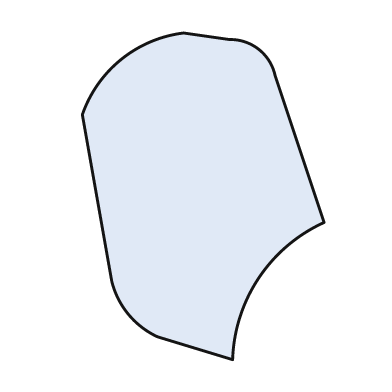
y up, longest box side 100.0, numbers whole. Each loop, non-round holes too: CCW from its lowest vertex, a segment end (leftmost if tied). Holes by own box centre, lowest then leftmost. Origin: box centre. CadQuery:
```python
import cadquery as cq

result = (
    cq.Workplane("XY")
    .moveTo(9.0, -50.0)
    .threePointArc((17.0, -25.0), (37.0, -8.0))
    .lineTo(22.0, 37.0)
    .threePointArc((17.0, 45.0), (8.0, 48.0))
    .lineTo(-6.0, 50.0)
    .threePointArc((-25.0, 42.0), (-37.0, 25.0))
    .lineTo(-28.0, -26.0)
    .threePointArc((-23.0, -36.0), (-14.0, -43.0))
    .close()
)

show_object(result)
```